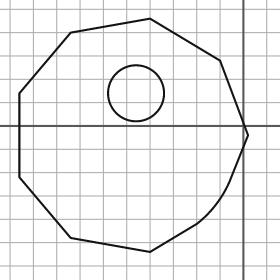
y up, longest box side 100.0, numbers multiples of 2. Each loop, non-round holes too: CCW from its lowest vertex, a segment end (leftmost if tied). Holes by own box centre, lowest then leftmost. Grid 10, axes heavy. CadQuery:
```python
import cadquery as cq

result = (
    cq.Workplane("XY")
    .moveTo(-40.0, -54.0)
    .lineTo(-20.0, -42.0)
    .threePointArc((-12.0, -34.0), (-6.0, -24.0))
    .lineTo(2.0, -4.0)
    .lineTo(-10.0, 28.0)
    .lineTo(-40.0, 46.0)
    .lineTo(-74.0, 40.0)
    .lineTo(-96.0, 14.0)
    .lineTo(-96.0, -22.0)
    .lineTo(-74.0, -48.0)
    .close()
    .moveTo(-46.0, 14.0)
    .circle(12.0)
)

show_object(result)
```